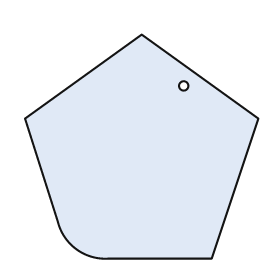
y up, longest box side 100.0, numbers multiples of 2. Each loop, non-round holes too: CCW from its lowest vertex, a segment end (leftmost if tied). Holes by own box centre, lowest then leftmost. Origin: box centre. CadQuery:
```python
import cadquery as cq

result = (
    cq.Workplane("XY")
    .moveTo(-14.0, -48.0)
    .lineTo(30.0, -48.0)
    .lineTo(50.0, 12.0)
    .lineTo(0.0, 48.0)
    .lineTo(-50.0, 12.0)
    .lineTo(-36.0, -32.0)
    .threePointArc((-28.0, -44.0), (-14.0, -48.0))
    .close()
    .moveTo(18.0, 26.0)
    .circle(2.0)
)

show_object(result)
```